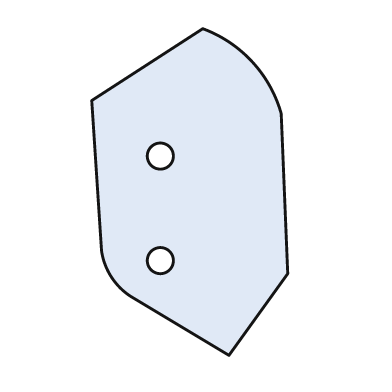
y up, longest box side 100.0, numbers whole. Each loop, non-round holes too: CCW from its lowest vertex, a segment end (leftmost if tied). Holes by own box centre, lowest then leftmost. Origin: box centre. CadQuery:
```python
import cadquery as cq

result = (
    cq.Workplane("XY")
    .moveTo(12.0, -50.0)
    .lineTo(30.0, -25.0)
    .lineTo(28.0, 24.0)
    .threePointArc((19.0, 40.0), (4.0, 50.0))
    .lineTo(-30.0, 28.0)
    .lineTo(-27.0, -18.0)
    .threePointArc((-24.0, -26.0), (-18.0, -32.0))
    .close()
    .moveTo(-9.0, -21.0)
    .circle(4.0)
    .moveTo(-9.0, 11.0)
    .circle(4.0)
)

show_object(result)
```